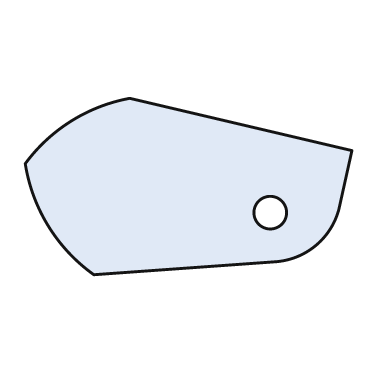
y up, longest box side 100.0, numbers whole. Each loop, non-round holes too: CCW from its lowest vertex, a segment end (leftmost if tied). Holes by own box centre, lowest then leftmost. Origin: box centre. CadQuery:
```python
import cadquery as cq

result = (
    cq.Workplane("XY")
    .moveTo(-29.0, -27.0)
    .lineTo(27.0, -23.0)
    .threePointArc((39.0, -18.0), (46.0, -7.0))
    .lineTo(50.0, 11.0)
    .lineTo(-18.0, 27.0)
    .threePointArc((-36.0, 20.0), (-50.0, 7.0))
    .threePointArc((-43.0, -12.0), (-29.0, -27.0))
    .close()
    .moveTo(25.0, -8.0)
    .circle(5.0)
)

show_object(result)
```